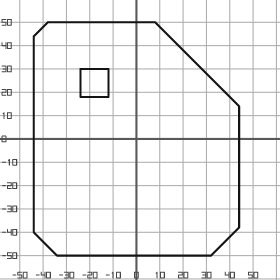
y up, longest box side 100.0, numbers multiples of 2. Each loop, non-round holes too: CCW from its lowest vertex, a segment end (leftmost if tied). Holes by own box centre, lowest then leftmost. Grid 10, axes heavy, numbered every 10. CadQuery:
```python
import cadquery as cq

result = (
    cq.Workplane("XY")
    .moveTo(-34.0, -50.0)
    .lineTo(32.0, -50.0)
    .lineTo(44.0, -38.0)
    .lineTo(44.0, 14.0)
    .lineTo(8.0, 50.0)
    .lineTo(-38.0, 50.0)
    .lineTo(-44.0, 44.0)
    .lineTo(-44.0, -40.0)
    .close()
    .moveTo(-24.0, 18.0)
    .lineTo(-12.0, 18.0)
    .lineTo(-12.0, 30.0)
    .lineTo(-24.0, 30.0)
    .close()
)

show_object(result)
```